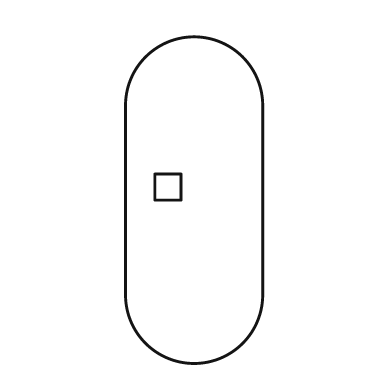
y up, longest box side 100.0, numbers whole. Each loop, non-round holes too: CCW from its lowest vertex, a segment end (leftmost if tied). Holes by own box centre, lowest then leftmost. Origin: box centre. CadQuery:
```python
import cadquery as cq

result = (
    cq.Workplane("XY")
    .moveTo(-21.0, -29.0)
    .threePointArc((0.0, -50.0), (21.0, -29.0))
    .lineTo(21.0, 29.0)
    .threePointArc((0.0, 50.0), (-21.0, 29.0))
    .close()
    .moveTo(-12.0, 0.0)
    .lineTo(-4.0, 0.0)
    .lineTo(-4.0, 8.0)
    .lineTo(-12.0, 8.0)
    .close()
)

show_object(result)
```